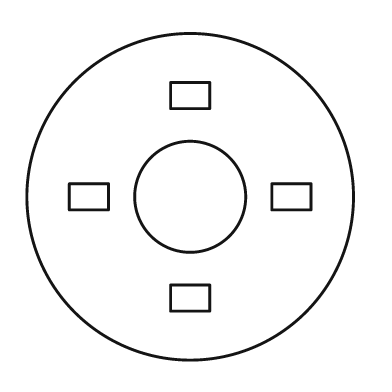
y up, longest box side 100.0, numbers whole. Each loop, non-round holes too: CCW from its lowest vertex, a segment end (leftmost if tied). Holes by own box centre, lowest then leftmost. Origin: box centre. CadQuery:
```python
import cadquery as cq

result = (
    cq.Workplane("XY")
    .moveTo(0.0, 0.0)
    .circle(50.0)
    .moveTo(-6.0, -35.0)
    .lineTo(6.0, -35.0)
    .lineTo(6.0, -27.0)
    .lineTo(-6.0, -27.0)
    .close()
    .moveTo(-37.0, -4.0)
    .lineTo(-25.0, -4.0)
    .lineTo(-25.0, 4.0)
    .lineTo(-37.0, 4.0)
    .close()
    .moveTo(0.0, 0.0)
    .circle(17.0)
    .moveTo(25.0, -4.0)
    .lineTo(37.0, -4.0)
    .lineTo(37.0, 4.0)
    .lineTo(25.0, 4.0)
    .close()
    .moveTo(-6.0, 27.0)
    .lineTo(6.0, 27.0)
    .lineTo(6.0, 35.0)
    .lineTo(-6.0, 35.0)
    .close()
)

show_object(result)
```